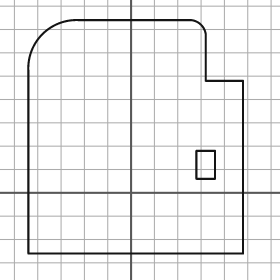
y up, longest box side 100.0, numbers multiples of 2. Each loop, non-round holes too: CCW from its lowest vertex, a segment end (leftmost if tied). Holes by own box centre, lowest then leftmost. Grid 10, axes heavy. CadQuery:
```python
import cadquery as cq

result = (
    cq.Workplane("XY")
    .moveTo(-44.0, -26.0)
    .lineTo(48.0, -26.0)
    .lineTo(48.0, 48.0)
    .lineTo(32.0, 48.0)
    .lineTo(32.0, 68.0)
    .threePointArc((30.0, 72.0), (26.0, 74.0))
    .lineTo(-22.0, 74.0)
    .threePointArc((-38.0, 68.0), (-44.0, 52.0))
    .close()
    .moveTo(28.0, 6.0)
    .lineTo(36.0, 6.0)
    .lineTo(36.0, 18.0)
    .lineTo(28.0, 18.0)
    .close()
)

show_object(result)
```